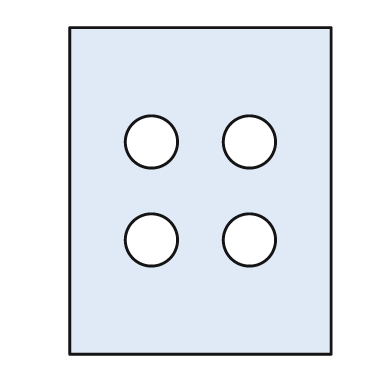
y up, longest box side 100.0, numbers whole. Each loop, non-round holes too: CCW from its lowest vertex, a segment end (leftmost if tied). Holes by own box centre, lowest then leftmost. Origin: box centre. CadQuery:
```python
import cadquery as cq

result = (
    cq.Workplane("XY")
    .moveTo(-40.0, -50.0)
    .lineTo(40.0, -50.0)
    .lineTo(40.0, 50.0)
    .lineTo(-40.0, 50.0)
    .close()
    .moveTo(-15.0, -15.0)
    .circle(8.0)
    .moveTo(15.0, -15.0)
    .circle(8.0)
    .moveTo(-15.0, 15.0)
    .circle(8.0)
    .moveTo(15.0, 15.0)
    .circle(8.0)
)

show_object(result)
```